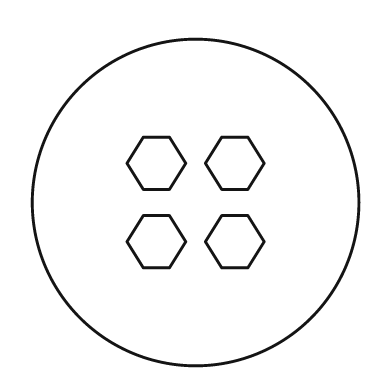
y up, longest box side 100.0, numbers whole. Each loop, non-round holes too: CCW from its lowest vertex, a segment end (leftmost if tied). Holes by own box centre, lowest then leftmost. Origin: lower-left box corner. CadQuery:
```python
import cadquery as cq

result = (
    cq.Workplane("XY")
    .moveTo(50.0, 50.0)
    .circle(50.0)
    .moveTo(34.0, 30.0)
    .lineTo(42.0, 30.0)
    .lineTo(47.0, 38.0)
    .lineTo(42.0, 46.0)
    .lineTo(34.0, 46.0)
    .lineTo(29.0, 38.0)
    .close()
    .moveTo(58.0, 30.0)
    .lineTo(66.0, 30.0)
    .lineTo(71.0, 38.0)
    .lineTo(66.0, 46.0)
    .lineTo(58.0, 46.0)
    .lineTo(53.0, 38.0)
    .close()
    .moveTo(34.0, 54.0)
    .lineTo(42.0, 54.0)
    .lineTo(47.0, 62.0)
    .lineTo(42.0, 70.0)
    .lineTo(34.0, 70.0)
    .lineTo(29.0, 62.0)
    .close()
    .moveTo(58.0, 54.0)
    .lineTo(66.0, 54.0)
    .lineTo(71.0, 62.0)
    .lineTo(66.0, 70.0)
    .lineTo(58.0, 70.0)
    .lineTo(53.0, 62.0)
    .close()
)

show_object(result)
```